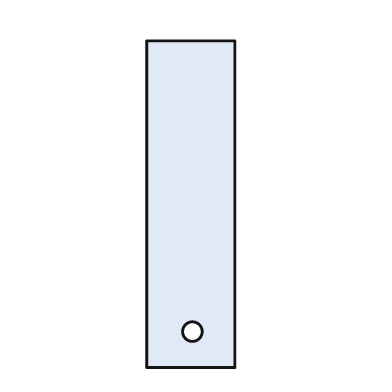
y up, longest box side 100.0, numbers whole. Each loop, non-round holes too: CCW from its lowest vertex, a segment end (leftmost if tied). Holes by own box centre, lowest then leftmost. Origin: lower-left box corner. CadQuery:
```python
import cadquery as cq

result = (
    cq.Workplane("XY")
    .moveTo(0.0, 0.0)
    .lineTo(27.0, 0.0)
    .lineTo(27.0, 100.0)
    .lineTo(0.0, 100.0)
    .close()
    .moveTo(14.0, 11.0)
    .circle(3.0)
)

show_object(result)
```